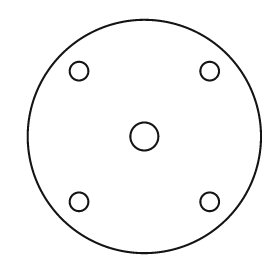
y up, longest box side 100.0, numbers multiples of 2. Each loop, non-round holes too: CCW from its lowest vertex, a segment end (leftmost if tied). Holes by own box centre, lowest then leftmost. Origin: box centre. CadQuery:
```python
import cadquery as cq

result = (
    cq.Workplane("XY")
    .moveTo(0.0, 0.0)
    .circle(50.0)
    .moveTo(-28.0, -28.0)
    .circle(4.0)
    .moveTo(28.0, -28.0)
    .circle(4.0)
    .moveTo(0.0, 0.0)
    .circle(6.0)
    .moveTo(-28.0, 28.0)
    .circle(4.0)
    .moveTo(28.0, 28.0)
    .circle(4.0)
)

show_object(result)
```